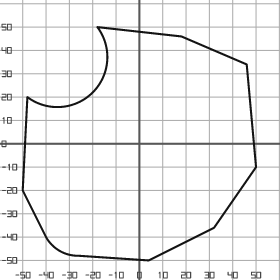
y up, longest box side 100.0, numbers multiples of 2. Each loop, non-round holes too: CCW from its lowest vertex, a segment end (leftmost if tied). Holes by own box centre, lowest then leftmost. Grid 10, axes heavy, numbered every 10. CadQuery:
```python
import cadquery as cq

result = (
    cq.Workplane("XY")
    .moveTo(4.0, -50.0)
    .lineTo(32.0, -36.0)
    .lineTo(50.0, -10.0)
    .lineTo(46.0, 34.0)
    .lineTo(18.0, 46.0)
    .lineTo(-18.0, 50.0)
    .threePointArc((-20.0, 22.0), (-48.0, 20.0))
    .lineTo(-50.0, -20.0)
    .lineTo(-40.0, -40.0)
    .threePointArc((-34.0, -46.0), (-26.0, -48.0))
    .close()
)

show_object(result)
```